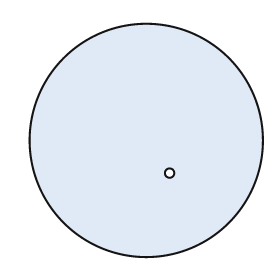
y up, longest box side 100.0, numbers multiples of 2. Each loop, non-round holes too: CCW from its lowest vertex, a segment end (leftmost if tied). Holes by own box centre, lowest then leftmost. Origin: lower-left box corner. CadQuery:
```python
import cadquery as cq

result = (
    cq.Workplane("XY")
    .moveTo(50.0, 50.0)
    .circle(50.0)
    .moveTo(60.0, 36.0)
    .circle(2.0)
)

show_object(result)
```